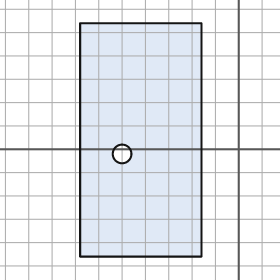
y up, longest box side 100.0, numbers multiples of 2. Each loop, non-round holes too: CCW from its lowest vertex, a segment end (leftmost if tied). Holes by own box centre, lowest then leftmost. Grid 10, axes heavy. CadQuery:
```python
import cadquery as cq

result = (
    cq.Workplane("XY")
    .moveTo(-68.0, -46.0)
    .lineTo(-16.0, -46.0)
    .lineTo(-16.0, 54.0)
    .lineTo(-68.0, 54.0)
    .close()
    .moveTo(-50.0, -2.0)
    .circle(4.0)
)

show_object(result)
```